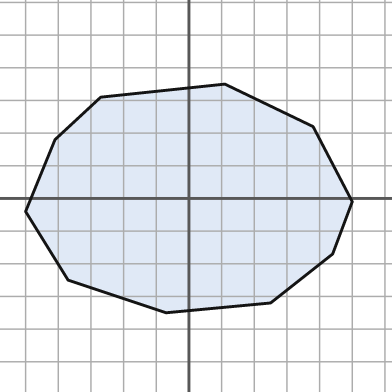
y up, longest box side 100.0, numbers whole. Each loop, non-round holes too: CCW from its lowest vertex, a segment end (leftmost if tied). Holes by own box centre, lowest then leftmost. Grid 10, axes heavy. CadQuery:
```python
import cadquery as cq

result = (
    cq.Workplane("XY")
    .moveTo(-7.0, -35.0)
    .lineTo(25.0, -32.0)
    .lineTo(44.0, -17.0)
    .lineTo(50.0, -1.0)
    .lineTo(38.0, 22.0)
    .lineTo(11.0, 35.0)
    .lineTo(-27.0, 31.0)
    .lineTo(-41.0, 18.0)
    .lineTo(-50.0, -4.0)
    .lineTo(-37.0, -25.0)
    .close()
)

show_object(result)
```